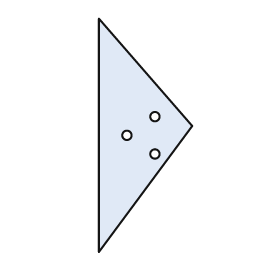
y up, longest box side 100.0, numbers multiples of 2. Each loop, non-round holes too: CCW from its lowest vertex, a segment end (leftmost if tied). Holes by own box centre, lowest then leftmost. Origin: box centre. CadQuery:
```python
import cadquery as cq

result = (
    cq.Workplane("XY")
    .moveTo(-20.0, -50.0)
    .lineTo(20.0, 4.0)
    .lineTo(-20.0, 50.0)
    .close()
    .moveTo(4.0, -8.0)
    .circle(2.0)
    .moveTo(-8.0, 0.0)
    .circle(2.0)
    .moveTo(4.0, 8.0)
    .circle(2.0)
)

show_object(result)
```